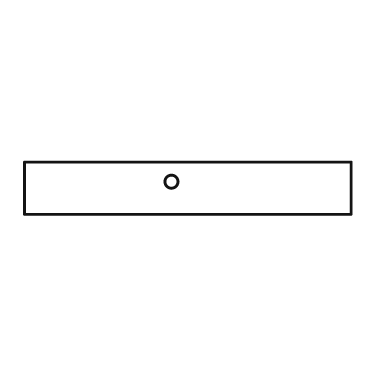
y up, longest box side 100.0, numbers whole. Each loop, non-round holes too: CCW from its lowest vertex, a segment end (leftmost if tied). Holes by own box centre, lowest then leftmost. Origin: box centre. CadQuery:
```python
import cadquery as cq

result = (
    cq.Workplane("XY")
    .moveTo(-50.0, -8.0)
    .lineTo(50.0, -8.0)
    .lineTo(50.0, 8.0)
    .lineTo(-50.0, 8.0)
    .close()
    .moveTo(-5.0, 2.0)
    .circle(2.0)
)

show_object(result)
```